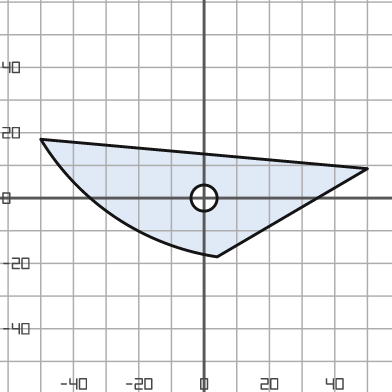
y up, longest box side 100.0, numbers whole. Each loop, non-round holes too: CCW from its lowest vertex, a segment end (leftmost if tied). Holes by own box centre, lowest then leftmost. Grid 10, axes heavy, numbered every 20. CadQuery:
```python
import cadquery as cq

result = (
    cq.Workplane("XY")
    .moveTo(4.0, -18.0)
    .lineTo(50.0, 9.0)
    .lineTo(-50.0, 18.0)
    .threePointArc((-27.0, -6.0), (4.0, -18.0))
    .close()
    .moveTo(0.0, 0.0)
    .circle(4.0)
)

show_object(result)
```